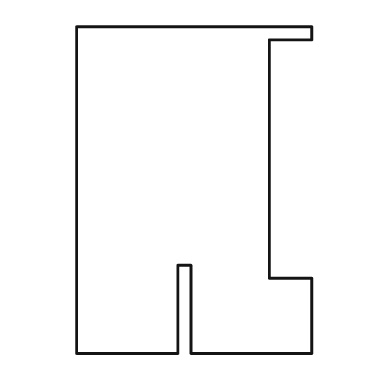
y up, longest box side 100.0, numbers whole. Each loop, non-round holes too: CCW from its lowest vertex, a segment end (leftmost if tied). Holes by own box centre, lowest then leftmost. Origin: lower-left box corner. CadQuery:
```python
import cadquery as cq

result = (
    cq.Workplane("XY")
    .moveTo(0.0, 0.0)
    .lineTo(31.0, 0.0)
    .lineTo(31.0, 27.0)
    .lineTo(35.0, 27.0)
    .lineTo(35.0, 0.0)
    .lineTo(72.0, 0.0)
    .lineTo(72.0, 23.0)
    .lineTo(59.0, 23.0)
    .lineTo(59.0, 96.0)
    .lineTo(72.0, 96.0)
    .lineTo(72.0, 100.0)
    .lineTo(0.0, 100.0)
    .close()
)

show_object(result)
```